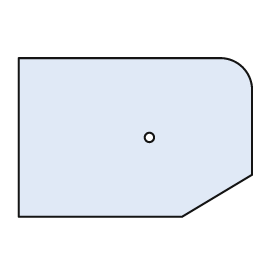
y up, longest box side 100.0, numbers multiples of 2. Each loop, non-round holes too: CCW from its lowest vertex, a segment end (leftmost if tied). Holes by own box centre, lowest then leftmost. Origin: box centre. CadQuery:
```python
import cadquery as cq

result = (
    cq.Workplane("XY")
    .moveTo(-50.0, -34.0)
    .lineTo(20.0, -34.0)
    .lineTo(50.0, -16.0)
    .lineTo(50.0, 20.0)
    .threePointArc((46.0, 30.0), (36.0, 34.0))
    .lineTo(-50.0, 34.0)
    .close()
    .moveTo(6.0, 0.0)
    .circle(2.0)
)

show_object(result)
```